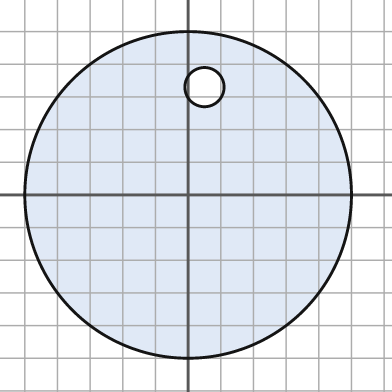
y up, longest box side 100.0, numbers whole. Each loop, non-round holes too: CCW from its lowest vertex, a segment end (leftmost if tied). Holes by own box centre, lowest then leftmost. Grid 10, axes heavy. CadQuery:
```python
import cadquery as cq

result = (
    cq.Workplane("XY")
    .moveTo(0.0, 0.0)
    .circle(50.0)
    .moveTo(5.0, 33.0)
    .circle(6.0)
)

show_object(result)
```